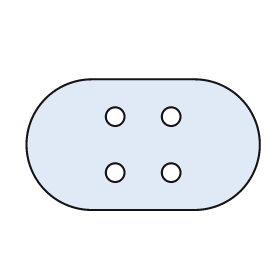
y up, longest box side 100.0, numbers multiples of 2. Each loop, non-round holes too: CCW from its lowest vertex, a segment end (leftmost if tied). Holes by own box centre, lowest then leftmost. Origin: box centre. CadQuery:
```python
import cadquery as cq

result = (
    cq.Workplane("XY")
    .moveTo(-22.0, -28.0)
    .lineTo(22.0, -28.0)
    .threePointArc((50.0, 0.0), (22.0, 28.0))
    .lineTo(-22.0, 28.0)
    .threePointArc((-50.0, 0.0), (-22.0, -28.0))
    .close()
    .moveTo(-12.0, -12.0)
    .circle(4.0)
    .moveTo(12.0, -12.0)
    .circle(4.0)
    .moveTo(-12.0, 12.0)
    .circle(4.0)
    .moveTo(12.0, 12.0)
    .circle(4.0)
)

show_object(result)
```